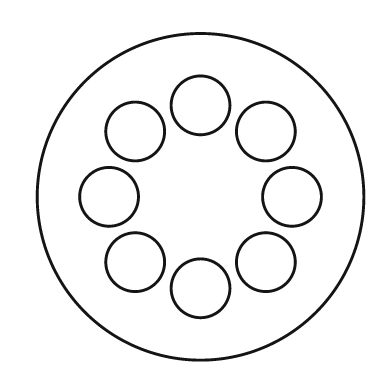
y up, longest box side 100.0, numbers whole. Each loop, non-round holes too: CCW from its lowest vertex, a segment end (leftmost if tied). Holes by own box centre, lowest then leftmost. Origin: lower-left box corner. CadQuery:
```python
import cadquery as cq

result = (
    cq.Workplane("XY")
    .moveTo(50.0, 50.0)
    .circle(50.0)
    .moveTo(50.0, 22.0)
    .circle(9.0)
    .moveTo(30.0, 30.0)
    .circle(9.0)
    .moveTo(70.0, 30.0)
    .circle(9.0)
    .moveTo(22.0, 50.0)
    .circle(9.0)
    .moveTo(78.0, 50.0)
    .circle(9.0)
    .moveTo(30.0, 70.0)
    .circle(9.0)
    .moveTo(70.0, 70.0)
    .circle(9.0)
    .moveTo(50.0, 78.0)
    .circle(9.0)
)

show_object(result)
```